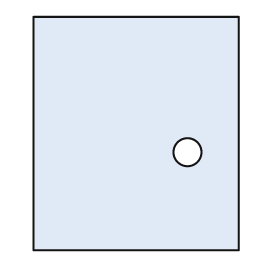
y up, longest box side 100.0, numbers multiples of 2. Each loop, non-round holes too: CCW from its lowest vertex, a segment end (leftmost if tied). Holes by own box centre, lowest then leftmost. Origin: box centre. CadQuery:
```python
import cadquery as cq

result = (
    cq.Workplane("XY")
    .moveTo(-44.0, -50.0)
    .lineTo(44.0, -50.0)
    .lineTo(44.0, 50.0)
    .lineTo(-44.0, 50.0)
    .close()
    .moveTo(22.0, -8.0)
    .circle(6.0)
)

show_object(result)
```